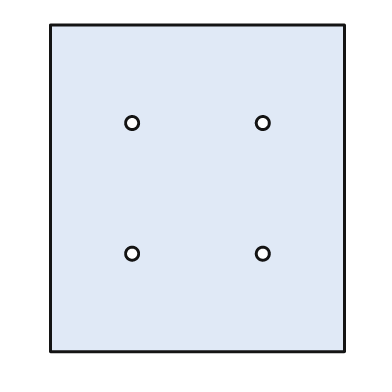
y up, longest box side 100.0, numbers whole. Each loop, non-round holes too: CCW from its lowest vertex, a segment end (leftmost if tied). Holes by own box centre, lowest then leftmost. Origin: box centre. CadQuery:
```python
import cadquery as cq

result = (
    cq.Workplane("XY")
    .moveTo(-45.0, -50.0)
    .lineTo(45.0, -50.0)
    .lineTo(45.0, 50.0)
    .lineTo(-45.0, 50.0)
    .close()
    .moveTo(-20.0, -20.0)
    .circle(2.0)
    .moveTo(20.0, -20.0)
    .circle(2.0)
    .moveTo(-20.0, 20.0)
    .circle(2.0)
    .moveTo(20.0, 20.0)
    .circle(2.0)
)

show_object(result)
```